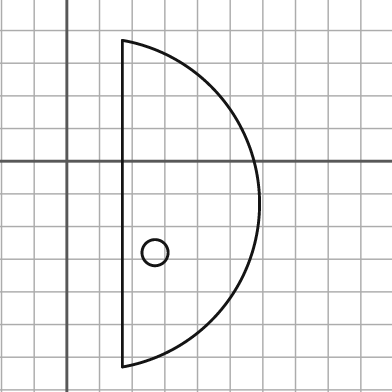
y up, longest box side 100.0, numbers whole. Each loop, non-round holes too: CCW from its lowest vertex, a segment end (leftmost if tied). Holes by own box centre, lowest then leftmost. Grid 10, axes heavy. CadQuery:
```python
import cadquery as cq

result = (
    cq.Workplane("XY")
    .moveTo(17.0, -63.0)
    .threePointArc((59.0, -13.0), (17.0, 37.0))
    .close()
    .moveTo(27.0, -28.0)
    .circle(4.0)
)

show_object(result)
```